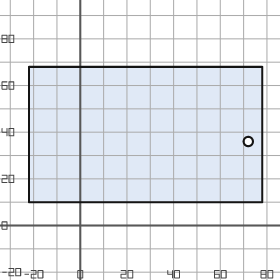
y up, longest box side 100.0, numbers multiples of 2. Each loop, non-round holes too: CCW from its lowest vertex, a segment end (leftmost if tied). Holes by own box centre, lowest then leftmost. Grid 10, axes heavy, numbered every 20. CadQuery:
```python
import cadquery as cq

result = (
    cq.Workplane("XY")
    .moveTo(-22.0, 10.0)
    .lineTo(78.0, 10.0)
    .lineTo(78.0, 68.0)
    .lineTo(-22.0, 68.0)
    .close()
    .moveTo(72.0, 36.0)
    .circle(2.0)
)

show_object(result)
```